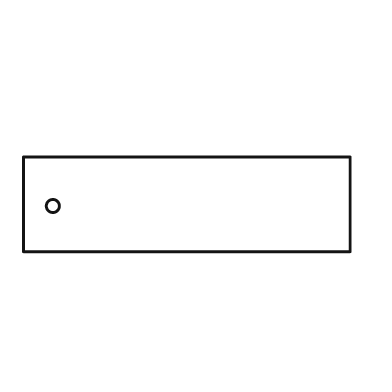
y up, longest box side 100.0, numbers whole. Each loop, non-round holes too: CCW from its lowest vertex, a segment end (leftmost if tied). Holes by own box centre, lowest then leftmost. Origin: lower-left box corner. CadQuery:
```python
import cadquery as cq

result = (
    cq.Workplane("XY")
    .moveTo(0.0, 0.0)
    .lineTo(100.0, 0.0)
    .lineTo(100.0, 29.0)
    .lineTo(0.0, 29.0)
    .close()
    .moveTo(9.0, 14.0)
    .circle(2.0)
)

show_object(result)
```